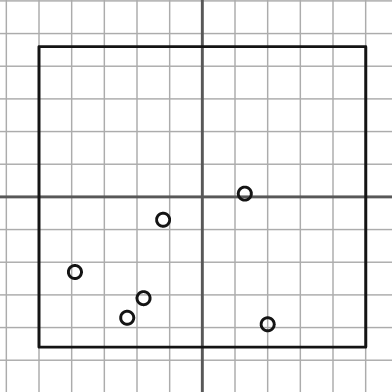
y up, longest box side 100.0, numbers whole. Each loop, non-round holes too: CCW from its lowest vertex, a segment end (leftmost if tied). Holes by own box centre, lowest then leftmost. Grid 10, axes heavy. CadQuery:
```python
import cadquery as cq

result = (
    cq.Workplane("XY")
    .moveTo(-50.0, -46.0)
    .lineTo(50.0, -46.0)
    .lineTo(50.0, 46.0)
    .lineTo(-50.0, 46.0)
    .close()
    .moveTo(20.0, -39.0)
    .circle(2.0)
    .moveTo(-23.0, -37.0)
    .circle(2.0)
    .moveTo(-18.0, -31.0)
    .circle(2.0)
    .moveTo(-39.0, -23.0)
    .circle(2.0)
    .moveTo(-12.0, -7.0)
    .circle(2.0)
    .moveTo(13.0, 1.0)
    .circle(2.0)
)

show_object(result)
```